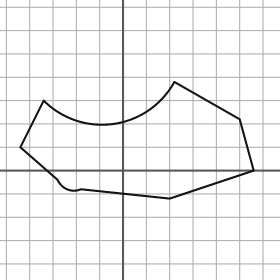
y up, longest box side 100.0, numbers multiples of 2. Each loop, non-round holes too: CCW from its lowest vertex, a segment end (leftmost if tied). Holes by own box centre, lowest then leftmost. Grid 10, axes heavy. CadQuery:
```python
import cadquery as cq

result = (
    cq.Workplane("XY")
    .moveTo(20.0, -12.0)
    .lineTo(56.0, 0.0)
    .lineTo(50.0, 22.0)
    .lineTo(22.0, 38.0)
    .threePointArc((-4.0, 20.0), (-34.0, 30.0))
    .lineTo(-44.0, 10.0)
    .lineTo(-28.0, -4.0)
    .threePointArc((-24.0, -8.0), (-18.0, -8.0))
    .close()
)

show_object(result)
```